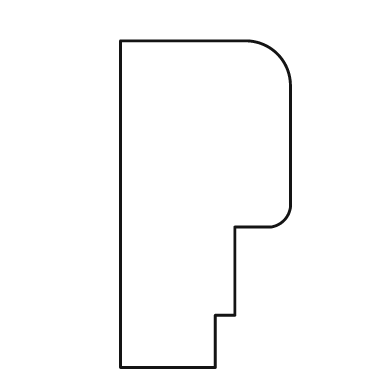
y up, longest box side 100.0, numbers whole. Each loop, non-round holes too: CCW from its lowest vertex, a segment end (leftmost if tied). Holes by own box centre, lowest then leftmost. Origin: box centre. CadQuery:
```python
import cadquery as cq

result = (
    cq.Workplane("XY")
    .moveTo(-26.0, -50.0)
    .lineTo(3.0, -50.0)
    .lineTo(3.0, -34.0)
    .lineTo(9.0, -34.0)
    .lineTo(9.0, -7.0)
    .lineTo(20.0, -7.0)
    .threePointArc((24.0, -5.0), (26.0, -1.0))
    .lineTo(26.0, 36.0)
    .threePointArc((22.0, 46.0), (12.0, 50.0))
    .lineTo(-26.0, 50.0)
    .close()
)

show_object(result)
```